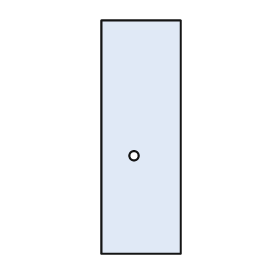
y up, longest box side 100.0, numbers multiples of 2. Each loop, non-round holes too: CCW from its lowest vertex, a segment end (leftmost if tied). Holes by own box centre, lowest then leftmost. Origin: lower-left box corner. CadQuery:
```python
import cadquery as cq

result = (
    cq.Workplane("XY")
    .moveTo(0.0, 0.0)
    .lineTo(34.0, 0.0)
    .lineTo(34.0, 100.0)
    .lineTo(0.0, 100.0)
    .close()
    .moveTo(14.0, 42.0)
    .circle(2.0)
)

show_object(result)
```